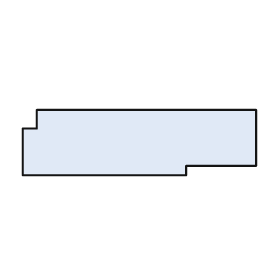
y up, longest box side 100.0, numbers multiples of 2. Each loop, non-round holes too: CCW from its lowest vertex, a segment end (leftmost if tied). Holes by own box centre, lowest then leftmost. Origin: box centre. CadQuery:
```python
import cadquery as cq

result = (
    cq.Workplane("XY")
    .moveTo(-50.0, -14.0)
    .lineTo(20.0, -14.0)
    .lineTo(20.0, -10.0)
    .lineTo(50.0, -10.0)
    .lineTo(50.0, 14.0)
    .lineTo(-44.0, 14.0)
    .lineTo(-44.0, 6.0)
    .lineTo(-50.0, 6.0)
    .close()
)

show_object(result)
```